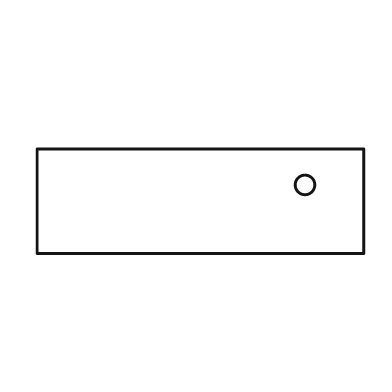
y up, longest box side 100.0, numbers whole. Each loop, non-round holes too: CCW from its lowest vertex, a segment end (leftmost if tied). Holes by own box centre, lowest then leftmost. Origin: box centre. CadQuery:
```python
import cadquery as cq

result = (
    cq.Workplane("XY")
    .moveTo(-50.0, -16.0)
    .lineTo(50.0, -16.0)
    .lineTo(50.0, 16.0)
    .lineTo(-50.0, 16.0)
    .close()
    .moveTo(32.0, 5.0)
    .circle(3.0)
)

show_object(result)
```